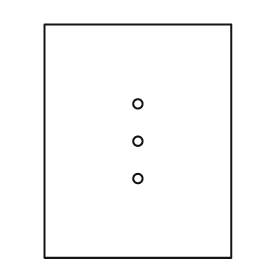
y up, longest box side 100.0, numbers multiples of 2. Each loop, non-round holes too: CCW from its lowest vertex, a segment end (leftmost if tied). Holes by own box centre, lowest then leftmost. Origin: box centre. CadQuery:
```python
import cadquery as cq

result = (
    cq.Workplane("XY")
    .moveTo(-40.0, -50.0)
    .lineTo(40.0, -50.0)
    .lineTo(40.0, 50.0)
    .lineTo(-40.0, 50.0)
    .close()
    .moveTo(0.0, -16.0)
    .circle(2.0)
    .moveTo(0.0, 0.0)
    .circle(2.0)
    .moveTo(0.0, 16.0)
    .circle(2.0)
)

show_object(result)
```